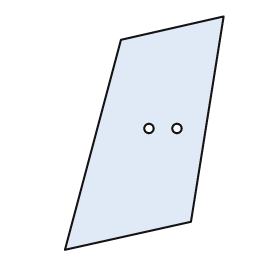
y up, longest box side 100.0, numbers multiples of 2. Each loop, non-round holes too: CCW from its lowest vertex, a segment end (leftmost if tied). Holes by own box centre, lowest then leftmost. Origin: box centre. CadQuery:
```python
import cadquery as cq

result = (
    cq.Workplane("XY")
    .moveTo(-34.0, -50.0)
    .lineTo(20.0, -38.0)
    .lineTo(34.0, 50.0)
    .lineTo(-10.0, 40.0)
    .close()
    .moveTo(2.0, 2.0)
    .circle(2.0)
    .moveTo(14.0, 2.0)
    .circle(2.0)
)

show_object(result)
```